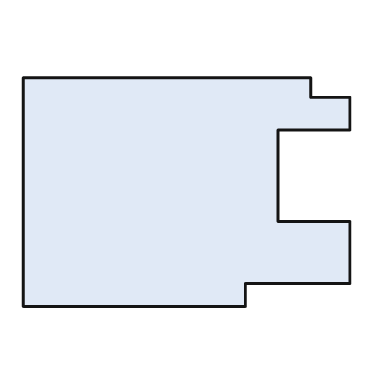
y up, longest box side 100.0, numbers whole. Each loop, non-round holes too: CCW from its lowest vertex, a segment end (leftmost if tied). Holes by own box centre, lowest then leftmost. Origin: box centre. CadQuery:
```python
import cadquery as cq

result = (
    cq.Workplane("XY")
    .moveTo(-50.0, -35.0)
    .lineTo(18.0, -35.0)
    .lineTo(18.0, -28.0)
    .lineTo(50.0, -28.0)
    .lineTo(50.0, -9.0)
    .lineTo(28.0, -9.0)
    .lineTo(28.0, 19.0)
    .lineTo(50.0, 19.0)
    .lineTo(50.0, 29.0)
    .lineTo(38.0, 29.0)
    .lineTo(38.0, 35.0)
    .lineTo(-50.0, 35.0)
    .close()
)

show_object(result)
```